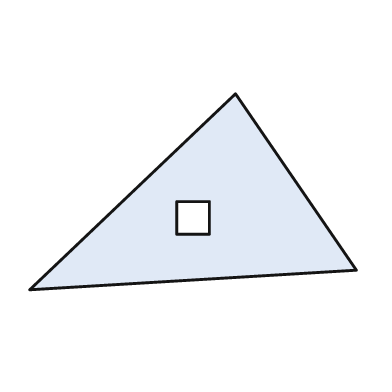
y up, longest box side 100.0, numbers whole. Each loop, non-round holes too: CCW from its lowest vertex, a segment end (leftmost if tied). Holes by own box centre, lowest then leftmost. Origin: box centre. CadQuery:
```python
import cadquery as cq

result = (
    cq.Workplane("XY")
    .moveTo(-50.0, -30.0)
    .lineTo(50.0, -24.0)
    .lineTo(13.0, 30.0)
    .close()
    .moveTo(-5.0, -13.0)
    .lineTo(5.0, -13.0)
    .lineTo(5.0, -3.0)
    .lineTo(-5.0, -3.0)
    .close()
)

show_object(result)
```